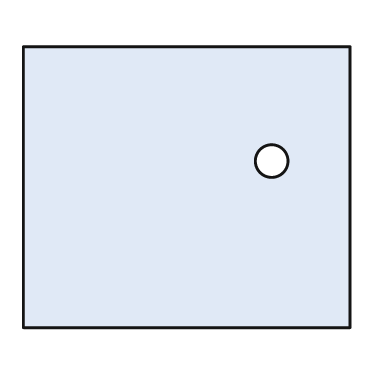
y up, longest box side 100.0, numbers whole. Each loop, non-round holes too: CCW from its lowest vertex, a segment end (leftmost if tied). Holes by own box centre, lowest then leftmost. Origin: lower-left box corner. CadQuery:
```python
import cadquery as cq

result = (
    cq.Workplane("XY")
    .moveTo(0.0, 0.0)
    .lineTo(100.0, 0.0)
    .lineTo(100.0, 86.0)
    .lineTo(0.0, 86.0)
    .close()
    .moveTo(76.0, 51.0)
    .circle(5.0)
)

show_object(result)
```